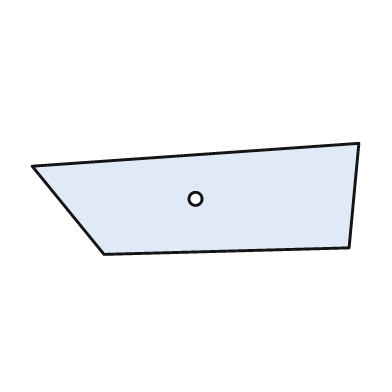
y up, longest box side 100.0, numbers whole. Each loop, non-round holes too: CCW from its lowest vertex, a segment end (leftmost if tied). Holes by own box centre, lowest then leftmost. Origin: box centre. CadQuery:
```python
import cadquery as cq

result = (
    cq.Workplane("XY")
    .moveTo(-28.0, -17.0)
    .lineTo(47.0, -15.0)
    .lineTo(50.0, 17.0)
    .lineTo(-50.0, 10.0)
    .close()
    .moveTo(0.0, 0.0)
    .circle(2.0)
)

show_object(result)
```